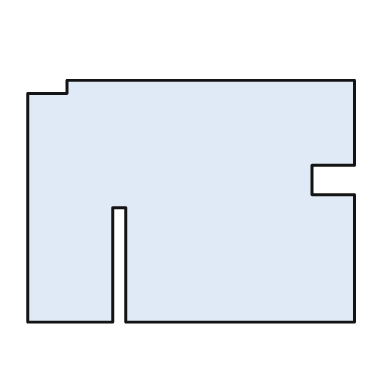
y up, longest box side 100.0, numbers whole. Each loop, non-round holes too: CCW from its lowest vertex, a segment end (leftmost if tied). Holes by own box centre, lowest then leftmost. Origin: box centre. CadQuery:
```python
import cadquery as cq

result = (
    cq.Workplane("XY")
    .moveTo(-50.0, -37.0)
    .lineTo(-24.0, -37.0)
    .lineTo(-24.0, -2.0)
    .lineTo(-20.0, -2.0)
    .lineTo(-20.0, -37.0)
    .lineTo(50.0, -37.0)
    .lineTo(50.0, 2.0)
    .lineTo(37.0, 2.0)
    .lineTo(37.0, 11.0)
    .lineTo(50.0, 11.0)
    .lineTo(50.0, 37.0)
    .lineTo(-38.0, 37.0)
    .lineTo(-38.0, 33.0)
    .lineTo(-50.0, 33.0)
    .close()
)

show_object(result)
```